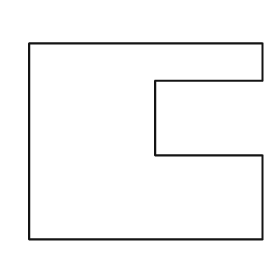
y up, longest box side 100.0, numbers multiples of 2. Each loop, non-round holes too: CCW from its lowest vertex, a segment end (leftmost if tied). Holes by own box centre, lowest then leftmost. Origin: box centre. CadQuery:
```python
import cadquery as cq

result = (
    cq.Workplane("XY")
    .moveTo(-50.0, -42.0)
    .lineTo(50.0, -42.0)
    .lineTo(50.0, -6.0)
    .lineTo(4.0, -6.0)
    .lineTo(4.0, 26.0)
    .lineTo(50.0, 26.0)
    .lineTo(50.0, 42.0)
    .lineTo(-50.0, 42.0)
    .close()
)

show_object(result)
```